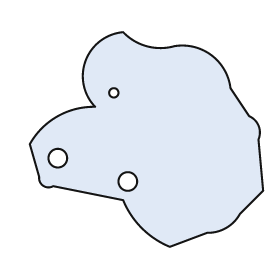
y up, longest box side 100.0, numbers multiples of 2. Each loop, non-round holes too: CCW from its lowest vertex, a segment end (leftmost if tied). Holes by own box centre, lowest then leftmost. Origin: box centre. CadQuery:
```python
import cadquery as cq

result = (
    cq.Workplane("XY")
    .moveTo(10.0, -46.0)
    .lineTo(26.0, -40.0)
    .threePointArc((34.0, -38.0), (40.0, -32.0))
    .lineTo(50.0, -22.0)
    .lineTo(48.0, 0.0)
    .threePointArc((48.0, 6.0), (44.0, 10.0))
    .lineTo(36.0, 22.0)
    .threePointArc((28.0, 36.0), (12.0, 40.0))
    .threePointArc((0.0, 40.0), (-10.0, 46.0))
    .threePointArc((-26.0, 34.0), (-22.0, 14.0))
    .threePointArc((-38.0, 10.0), (-50.0, -2.0))
    .lineTo(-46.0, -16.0)
    .threePointArc((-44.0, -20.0), (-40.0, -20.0))
    .lineTo(-10.0, -26.0)
    .threePointArc((-2.0, -38.0), (10.0, -46.0))
    .close()
    .moveTo(-8.0, -18.0)
    .circle(4.0)
    .moveTo(-38.0, -8.0)
    .circle(4.0)
    .moveTo(-14.0, 20.0)
    .circle(2.0)
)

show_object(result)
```